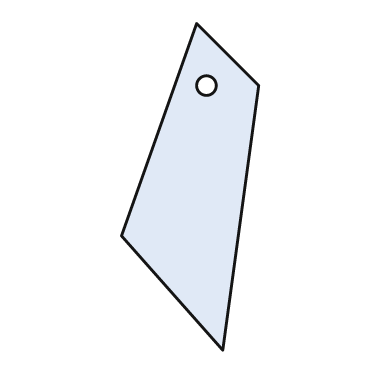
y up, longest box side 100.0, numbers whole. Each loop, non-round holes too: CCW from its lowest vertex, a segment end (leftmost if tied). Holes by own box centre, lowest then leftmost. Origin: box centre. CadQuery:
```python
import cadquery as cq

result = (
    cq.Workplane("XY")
    .moveTo(10.0, -50.0)
    .lineTo(21.0, 31.0)
    .lineTo(2.0, 50.0)
    .lineTo(-21.0, -15.0)
    .close()
    .moveTo(5.0, 31.0)
    .circle(3.0)
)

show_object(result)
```